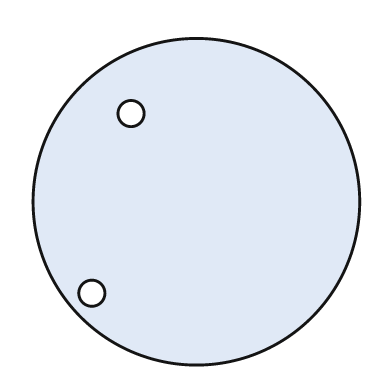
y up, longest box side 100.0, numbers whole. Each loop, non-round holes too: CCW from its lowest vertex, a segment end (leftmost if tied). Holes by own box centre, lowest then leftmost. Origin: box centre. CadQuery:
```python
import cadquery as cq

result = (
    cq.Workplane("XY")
    .moveTo(0.0, 0.0)
    .circle(50.0)
    .moveTo(-32.0, -28.0)
    .circle(4.0)
    .moveTo(-20.0, 27.0)
    .circle(4.0)
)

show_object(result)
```